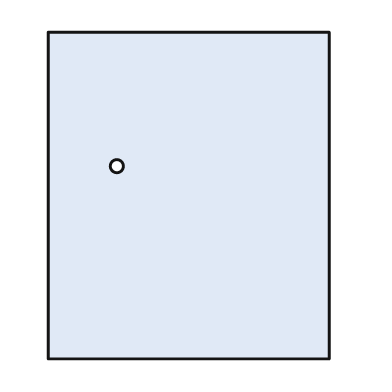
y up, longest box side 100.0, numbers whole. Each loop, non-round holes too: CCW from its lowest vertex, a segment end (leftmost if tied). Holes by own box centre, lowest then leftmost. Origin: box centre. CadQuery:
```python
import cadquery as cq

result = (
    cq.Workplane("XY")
    .moveTo(-43.0, -50.0)
    .lineTo(43.0, -50.0)
    .lineTo(43.0, 50.0)
    .lineTo(-43.0, 50.0)
    .close()
    .moveTo(-22.0, 9.0)
    .circle(2.0)
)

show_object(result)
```